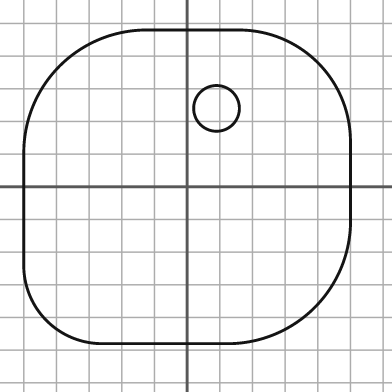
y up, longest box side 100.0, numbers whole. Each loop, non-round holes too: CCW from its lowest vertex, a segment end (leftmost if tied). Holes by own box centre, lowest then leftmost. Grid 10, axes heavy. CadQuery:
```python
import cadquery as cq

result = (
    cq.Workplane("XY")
    .moveTo(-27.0, -48.0)
    .lineTo(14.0, -48.0)
    .threePointArc((39.0, -37.0), (50.0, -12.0))
    .lineTo(50.0, 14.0)
    .threePointArc((40.0, 38.0), (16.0, 48.0))
    .lineTo(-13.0, 48.0)
    .threePointArc((-39.0, 37.0), (-50.0, 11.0))
    .lineTo(-50.0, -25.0)
    .threePointArc((-43.0, -41.0), (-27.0, -48.0))
    .close()
    .moveTo(9.0, 24.0)
    .circle(7.0)
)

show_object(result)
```